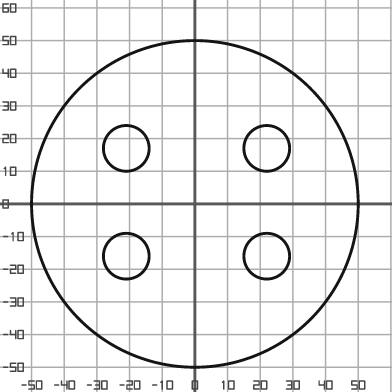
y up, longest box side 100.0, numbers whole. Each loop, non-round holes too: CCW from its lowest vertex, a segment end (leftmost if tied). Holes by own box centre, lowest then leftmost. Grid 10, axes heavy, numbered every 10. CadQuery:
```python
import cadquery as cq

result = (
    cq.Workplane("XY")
    .moveTo(0.0, 0.0)
    .circle(50.0)
    .moveTo(-21.0, -16.0)
    .circle(7.0)
    .moveTo(22.0, -16.0)
    .circle(7.0)
    .moveTo(-21.0, 17.0)
    .circle(7.0)
    .moveTo(22.0, 17.0)
    .circle(7.0)
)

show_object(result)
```